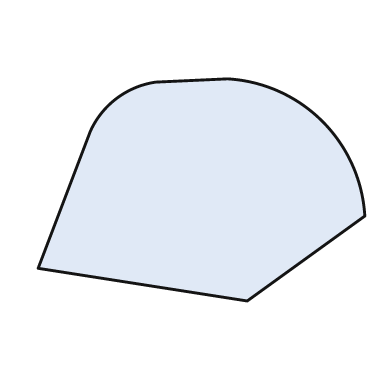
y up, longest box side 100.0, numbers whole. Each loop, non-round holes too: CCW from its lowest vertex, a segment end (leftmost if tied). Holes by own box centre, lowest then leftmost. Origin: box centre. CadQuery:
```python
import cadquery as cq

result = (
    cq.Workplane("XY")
    .moveTo(14.0, -34.0)
    .lineTo(50.0, -8.0)
    .threePointArc((37.0, 21.0), (8.0, 34.0))
    .lineTo(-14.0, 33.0)
    .threePointArc((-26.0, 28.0), (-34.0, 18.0))
    .lineTo(-50.0, -24.0)
    .close()
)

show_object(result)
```